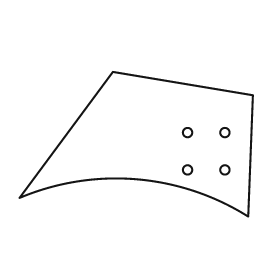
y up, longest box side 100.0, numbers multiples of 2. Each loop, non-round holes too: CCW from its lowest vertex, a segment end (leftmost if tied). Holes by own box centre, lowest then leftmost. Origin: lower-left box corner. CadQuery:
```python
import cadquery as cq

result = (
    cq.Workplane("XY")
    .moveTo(98.0, 0.0)
    .lineTo(100.0, 52.0)
    .lineTo(40.0, 62.0)
    .lineTo(0.0, 8.0)
    .threePointArc((50.0, 16.0), (98.0, 0.0))
    .close()
    .moveTo(72.0, 20.0)
    .circle(2.0)
    .moveTo(88.0, 20.0)
    .circle(2.0)
    .moveTo(72.0, 36.0)
    .circle(2.0)
    .moveTo(88.0, 36.0)
    .circle(2.0)
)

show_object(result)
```